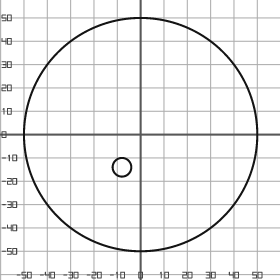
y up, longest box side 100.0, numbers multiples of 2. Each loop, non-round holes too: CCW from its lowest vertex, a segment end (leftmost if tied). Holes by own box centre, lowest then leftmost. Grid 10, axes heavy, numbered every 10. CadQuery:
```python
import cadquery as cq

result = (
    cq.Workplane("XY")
    .moveTo(0.0, 0.0)
    .circle(50.0)
    .moveTo(-8.0, -14.0)
    .circle(4.0)
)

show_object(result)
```